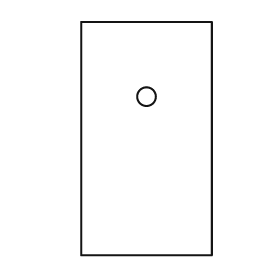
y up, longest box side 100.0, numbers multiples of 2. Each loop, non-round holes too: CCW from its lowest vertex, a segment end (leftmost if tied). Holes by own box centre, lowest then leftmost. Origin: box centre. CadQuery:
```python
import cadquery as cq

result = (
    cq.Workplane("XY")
    .moveTo(-28.0, -50.0)
    .lineTo(28.0, -50.0)
    .lineTo(28.0, 50.0)
    .lineTo(-28.0, 50.0)
    .close()
    .moveTo(0.0, 18.0)
    .circle(4.0)
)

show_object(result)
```